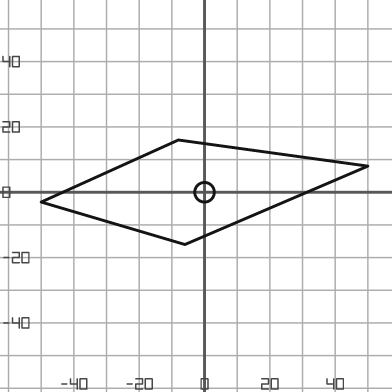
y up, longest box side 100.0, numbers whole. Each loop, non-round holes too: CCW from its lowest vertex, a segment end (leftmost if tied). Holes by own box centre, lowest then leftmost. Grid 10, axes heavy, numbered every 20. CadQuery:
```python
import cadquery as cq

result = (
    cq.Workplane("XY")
    .moveTo(-6.0, -16.0)
    .lineTo(50.0, 8.0)
    .lineTo(-8.0, 16.0)
    .lineTo(-50.0, -3.0)
    .close()
    .moveTo(0.0, 0.0)
    .circle(3.0)
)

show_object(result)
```